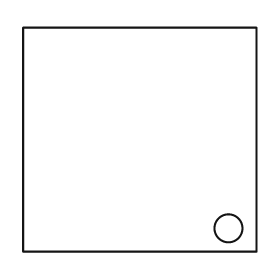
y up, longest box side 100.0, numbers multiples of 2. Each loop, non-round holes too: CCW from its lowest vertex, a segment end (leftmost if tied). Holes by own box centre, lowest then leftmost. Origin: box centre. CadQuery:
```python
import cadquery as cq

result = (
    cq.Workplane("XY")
    .moveTo(-50.0, -48.0)
    .lineTo(50.0, -48.0)
    .lineTo(50.0, 48.0)
    .lineTo(-50.0, 48.0)
    .close()
    .moveTo(38.0, -38.0)
    .circle(6.0)
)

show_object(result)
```